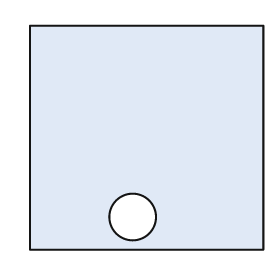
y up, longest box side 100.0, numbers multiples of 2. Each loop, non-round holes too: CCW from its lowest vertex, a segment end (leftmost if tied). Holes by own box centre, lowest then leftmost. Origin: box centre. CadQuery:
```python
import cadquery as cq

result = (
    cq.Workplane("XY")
    .moveTo(-50.0, -48.0)
    .lineTo(50.0, -48.0)
    .lineTo(50.0, 48.0)
    .lineTo(-50.0, 48.0)
    .close()
    .moveTo(-6.0, -34.0)
    .circle(10.0)
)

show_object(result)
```